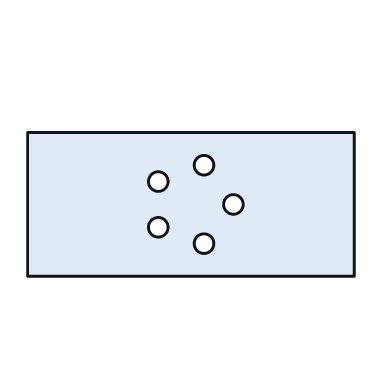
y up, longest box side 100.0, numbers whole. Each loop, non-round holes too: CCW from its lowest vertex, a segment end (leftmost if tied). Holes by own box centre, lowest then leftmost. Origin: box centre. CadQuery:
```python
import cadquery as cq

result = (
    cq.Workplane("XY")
    .moveTo(-50.0, -22.0)
    .lineTo(50.0, -22.0)
    .lineTo(50.0, 22.0)
    .lineTo(-50.0, 22.0)
    .close()
    .moveTo(4.0, -12.0)
    .circle(3.0)
    .moveTo(-10.0, -7.0)
    .circle(3.0)
    .moveTo(13.0, 0.0)
    .circle(3.0)
    .moveTo(-10.0, 7.0)
    .circle(3.0)
    .moveTo(4.0, 12.0)
    .circle(3.0)
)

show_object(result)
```